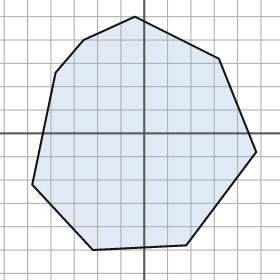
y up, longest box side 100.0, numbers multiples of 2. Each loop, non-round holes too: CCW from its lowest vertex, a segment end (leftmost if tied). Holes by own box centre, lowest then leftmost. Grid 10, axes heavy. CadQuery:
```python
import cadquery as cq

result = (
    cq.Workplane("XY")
    .moveTo(-22.0, -50.0)
    .lineTo(18.0, -48.0)
    .lineTo(48.0, -8.0)
    .lineTo(32.0, 32.0)
    .lineTo(-4.0, 50.0)
    .lineTo(-26.0, 40.0)
    .lineTo(-38.0, 26.0)
    .lineTo(-48.0, -22.0)
    .close()
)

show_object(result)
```